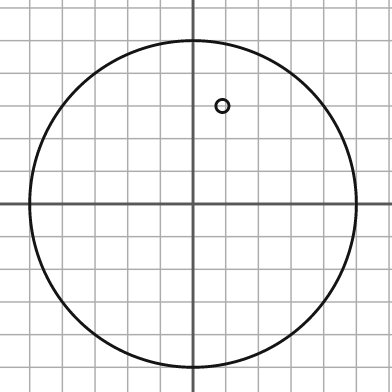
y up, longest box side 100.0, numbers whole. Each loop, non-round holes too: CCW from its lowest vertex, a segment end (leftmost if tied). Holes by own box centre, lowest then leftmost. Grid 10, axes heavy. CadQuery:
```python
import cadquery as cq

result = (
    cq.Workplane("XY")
    .moveTo(0.0, 0.0)
    .circle(50.0)
    .moveTo(9.0, 30.0)
    .circle(2.0)
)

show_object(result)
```